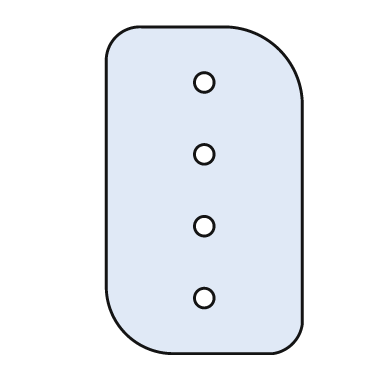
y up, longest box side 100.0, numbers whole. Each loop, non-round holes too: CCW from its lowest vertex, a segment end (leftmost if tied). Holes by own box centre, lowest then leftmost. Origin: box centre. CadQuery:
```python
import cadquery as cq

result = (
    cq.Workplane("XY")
    .moveTo(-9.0, -50.0)
    .lineTo(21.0, -50.0)
    .threePointArc((27.0, -47.0), (30.0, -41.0))
    .lineTo(30.0, 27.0)
    .threePointArc((23.0, 43.0), (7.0, 50.0))
    .lineTo(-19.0, 50.0)
    .threePointArc((-27.0, 47.0), (-30.0, 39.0))
    .lineTo(-30.0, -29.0)
    .threePointArc((-24.0, -44.0), (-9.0, -50.0))
    .close()
    .moveTo(0.0, -33.0)
    .circle(3.0)
    .moveTo(0.0, -11.0)
    .circle(3.0)
    .moveTo(0.0, 11.0)
    .circle(3.0)
    .moveTo(0.0, 33.0)
    .circle(3.0)
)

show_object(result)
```